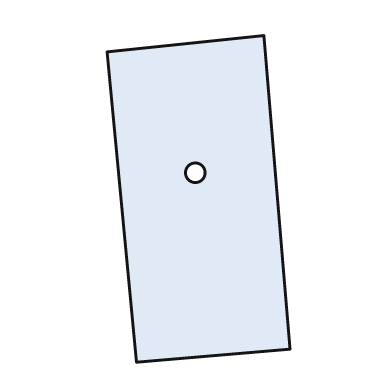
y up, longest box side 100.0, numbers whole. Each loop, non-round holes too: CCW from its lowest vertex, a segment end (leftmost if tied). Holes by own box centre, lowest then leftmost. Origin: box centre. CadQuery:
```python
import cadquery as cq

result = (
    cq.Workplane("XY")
    .moveTo(-19.0, -50.0)
    .lineTo(28.0, -46.0)
    .lineTo(20.0, 50.0)
    .lineTo(-28.0, 45.0)
    .close()
    .moveTo(-1.0, 8.0)
    .circle(3.0)
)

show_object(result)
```